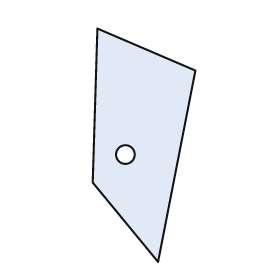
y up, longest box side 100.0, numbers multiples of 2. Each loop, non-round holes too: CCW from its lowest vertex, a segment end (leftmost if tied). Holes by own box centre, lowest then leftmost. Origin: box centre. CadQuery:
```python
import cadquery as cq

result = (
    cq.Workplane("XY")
    .moveTo(6.0, -50.0)
    .lineTo(22.0, 32.0)
    .lineTo(-20.0, 50.0)
    .lineTo(-22.0, -16.0)
    .close()
    .moveTo(-8.0, -4.0)
    .circle(4.0)
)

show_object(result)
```